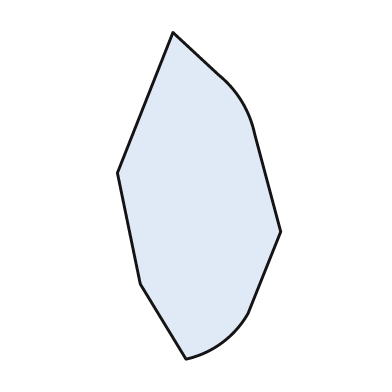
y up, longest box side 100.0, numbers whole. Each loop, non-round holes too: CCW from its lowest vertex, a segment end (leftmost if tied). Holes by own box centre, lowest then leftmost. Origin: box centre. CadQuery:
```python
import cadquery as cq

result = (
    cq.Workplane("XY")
    .moveTo(-4.0, -50.0)
    .threePointArc((7.0, -45.0), (15.0, -36.0))
    .lineTo(25.0, -11.0)
    .lineTo(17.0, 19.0)
    .threePointArc((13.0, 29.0), (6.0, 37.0))
    .lineTo(-8.0, 50.0)
    .lineTo(-25.0, 7.0)
    .lineTo(-18.0, -27.0)
    .close()
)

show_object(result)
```